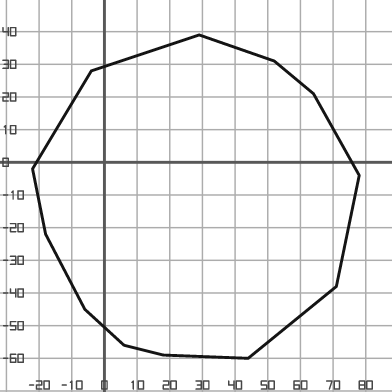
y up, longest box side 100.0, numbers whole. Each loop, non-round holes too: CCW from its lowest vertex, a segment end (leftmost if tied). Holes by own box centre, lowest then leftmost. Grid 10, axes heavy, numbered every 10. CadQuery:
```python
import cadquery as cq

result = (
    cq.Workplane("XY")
    .moveTo(44.0, -60.0)
    .lineTo(71.0, -38.0)
    .lineTo(78.0, -4.0)
    .lineTo(64.0, 21.0)
    .lineTo(52.0, 31.0)
    .lineTo(29.0, 39.0)
    .lineTo(-4.0, 28.0)
    .lineTo(-22.0, -2.0)
    .lineTo(-18.0, -22.0)
    .lineTo(-6.0, -45.0)
    .lineTo(6.0, -56.0)
    .lineTo(18.0, -59.0)
    .close()
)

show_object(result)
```